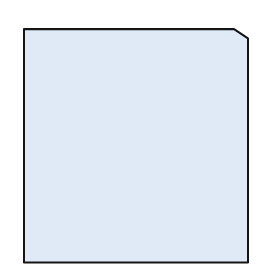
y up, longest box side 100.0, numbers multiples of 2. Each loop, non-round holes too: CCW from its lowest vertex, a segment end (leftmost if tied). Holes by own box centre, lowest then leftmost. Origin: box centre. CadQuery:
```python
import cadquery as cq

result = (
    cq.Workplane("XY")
    .moveTo(-48.0, -50.0)
    .lineTo(48.0, -50.0)
    .lineTo(48.0, 46.0)
    .lineTo(42.0, 50.0)
    .lineTo(-48.0, 50.0)
    .close()
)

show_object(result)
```